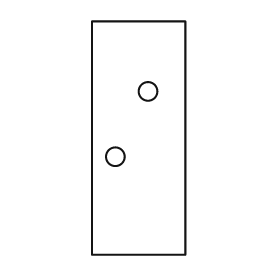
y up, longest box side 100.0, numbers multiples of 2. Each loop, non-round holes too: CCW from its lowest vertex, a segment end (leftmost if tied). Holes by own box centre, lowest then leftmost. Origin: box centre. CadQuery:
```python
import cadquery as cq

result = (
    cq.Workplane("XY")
    .moveTo(-20.0, -50.0)
    .lineTo(20.0, -50.0)
    .lineTo(20.0, 50.0)
    .lineTo(-20.0, 50.0)
    .close()
    .moveTo(-10.0, -8.0)
    .circle(4.0)
    .moveTo(4.0, 20.0)
    .circle(4.0)
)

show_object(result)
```